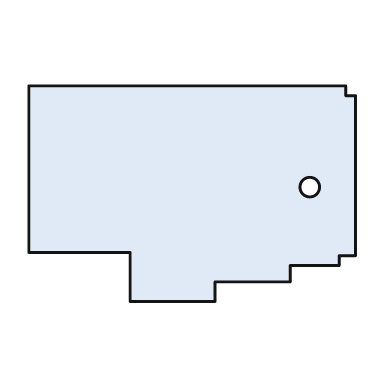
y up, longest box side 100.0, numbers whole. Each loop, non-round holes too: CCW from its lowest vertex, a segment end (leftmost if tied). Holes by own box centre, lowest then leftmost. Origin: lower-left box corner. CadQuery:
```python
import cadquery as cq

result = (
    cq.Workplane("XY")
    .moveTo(31.0, 0.0)
    .lineTo(57.0, 0.0)
    .lineTo(57.0, 6.0)
    .lineTo(80.0, 6.0)
    .lineTo(80.0, 11.0)
    .lineTo(95.0, 11.0)
    .lineTo(95.0, 14.0)
    .lineTo(100.0, 14.0)
    .lineTo(100.0, 63.0)
    .lineTo(97.0, 63.0)
    .lineTo(97.0, 66.0)
    .lineTo(0.0, 66.0)
    .lineTo(0.0, 15.0)
    .lineTo(31.0, 15.0)
    .close()
    .moveTo(86.0, 35.0)
    .circle(3.0)
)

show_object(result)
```